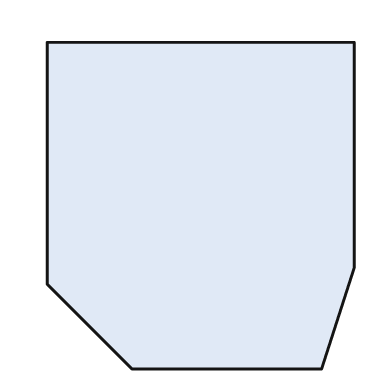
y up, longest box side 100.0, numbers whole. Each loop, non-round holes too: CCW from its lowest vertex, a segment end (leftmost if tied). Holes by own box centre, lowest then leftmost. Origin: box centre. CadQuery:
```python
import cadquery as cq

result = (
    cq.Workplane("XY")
    .moveTo(-21.0, -50.0)
    .lineTo(37.0, -50.0)
    .lineTo(47.0, -19.0)
    .lineTo(47.0, 50.0)
    .lineTo(-47.0, 50.0)
    .lineTo(-47.0, -24.0)
    .close()
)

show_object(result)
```